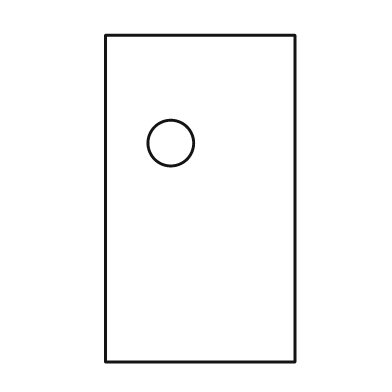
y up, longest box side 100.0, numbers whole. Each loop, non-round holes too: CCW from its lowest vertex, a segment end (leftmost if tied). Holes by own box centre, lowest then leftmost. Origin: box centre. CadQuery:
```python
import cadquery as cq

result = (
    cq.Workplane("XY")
    .moveTo(-29.0, -50.0)
    .lineTo(29.0, -50.0)
    .lineTo(29.0, 50.0)
    .lineTo(-29.0, 50.0)
    .close()
    .moveTo(-9.0, 17.0)
    .circle(7.0)
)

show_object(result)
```